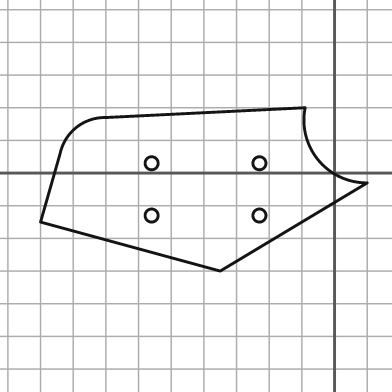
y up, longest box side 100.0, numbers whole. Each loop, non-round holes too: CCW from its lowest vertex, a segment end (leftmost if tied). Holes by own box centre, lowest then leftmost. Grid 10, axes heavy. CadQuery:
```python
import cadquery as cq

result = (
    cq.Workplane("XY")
    .moveTo(-35.0, -30.0)
    .lineTo(10.0, -3.0)
    .threePointArc((-5.0, 4.0), (-9.0, 20.0))
    .lineTo(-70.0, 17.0)
    .threePointArc((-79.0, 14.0), (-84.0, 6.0))
    .lineTo(-90.0, -15.0)
    .close()
    .moveTo(-56.0, -13.0)
    .circle(2.0)
    .moveTo(-23.0, -13.0)
    .circle(2.0)
    .moveTo(-56.0, 3.0)
    .circle(2.0)
    .moveTo(-23.0, 3.0)
    .circle(2.0)
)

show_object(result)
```